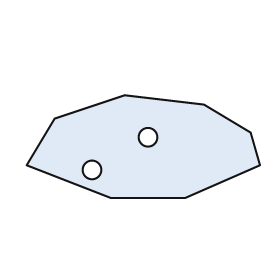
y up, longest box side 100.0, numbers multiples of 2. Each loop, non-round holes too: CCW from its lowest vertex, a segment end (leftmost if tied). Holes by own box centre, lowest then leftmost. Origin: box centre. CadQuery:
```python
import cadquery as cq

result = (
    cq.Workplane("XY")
    .moveTo(-14.0, -22.0)
    .lineTo(18.0, -22.0)
    .lineTo(50.0, -8.0)
    .lineTo(46.0, 6.0)
    .lineTo(26.0, 18.0)
    .lineTo(-8.0, 22.0)
    .lineTo(-38.0, 12.0)
    .lineTo(-50.0, -8.0)
    .close()
    .moveTo(-22.0, -10.0)
    .circle(4.0)
    .moveTo(2.0, 4.0)
    .circle(4.0)
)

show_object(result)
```